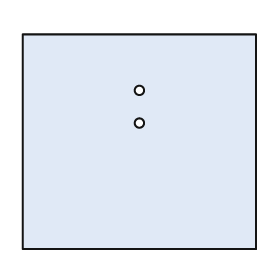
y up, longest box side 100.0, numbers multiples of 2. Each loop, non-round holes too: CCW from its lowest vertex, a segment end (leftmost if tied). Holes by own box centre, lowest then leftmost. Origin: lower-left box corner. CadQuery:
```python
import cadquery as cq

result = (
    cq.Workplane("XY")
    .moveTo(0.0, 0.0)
    .lineTo(100.0, 0.0)
    .lineTo(100.0, 92.0)
    .lineTo(0.0, 92.0)
    .close()
    .moveTo(50.0, 54.0)
    .circle(2.0)
    .moveTo(50.0, 68.0)
    .circle(2.0)
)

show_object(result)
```